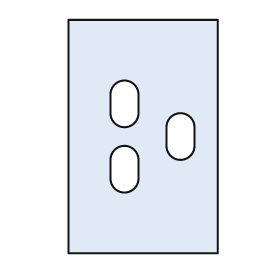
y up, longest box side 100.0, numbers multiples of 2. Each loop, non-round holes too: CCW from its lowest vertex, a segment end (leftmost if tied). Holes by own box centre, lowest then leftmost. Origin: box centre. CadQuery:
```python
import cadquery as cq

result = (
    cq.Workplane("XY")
    .moveTo(-32.0, -50.0)
    .lineTo(32.0, -50.0)
    .lineTo(32.0, 50.0)
    .lineTo(-32.0, 50.0)
    .close()
    .moveTo(-14.0, -18.0)
    .threePointArc((-8.0, -24.0), (-2.0, -18.0))
    .lineTo(-2.0, -10.0)
    .threePointArc((-8.0, -4.0), (-14.0, -10.0))
    .close()
    .moveTo(10.0, -4.0)
    .threePointArc((16.0, -10.0), (22.0, -4.0))
    .lineTo(22.0, 4.0)
    .threePointArc((16.0, 10.0), (10.0, 4.0))
    .close()
    .moveTo(-14.0, 10.0)
    .threePointArc((-8.0, 4.0), (-2.0, 10.0))
    .lineTo(-2.0, 18.0)
    .threePointArc((-8.0, 24.0), (-14.0, 18.0))
    .close()
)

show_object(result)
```